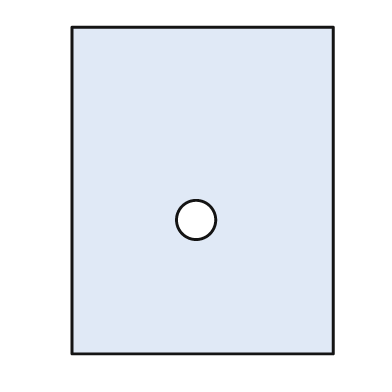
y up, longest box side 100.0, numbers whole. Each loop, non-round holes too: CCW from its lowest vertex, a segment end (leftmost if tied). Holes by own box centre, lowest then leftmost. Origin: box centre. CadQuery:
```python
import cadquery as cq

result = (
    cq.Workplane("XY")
    .moveTo(-40.0, -50.0)
    .lineTo(40.0, -50.0)
    .lineTo(40.0, 50.0)
    .lineTo(-40.0, 50.0)
    .close()
    .moveTo(-2.0, -9.0)
    .circle(6.0)
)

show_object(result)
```